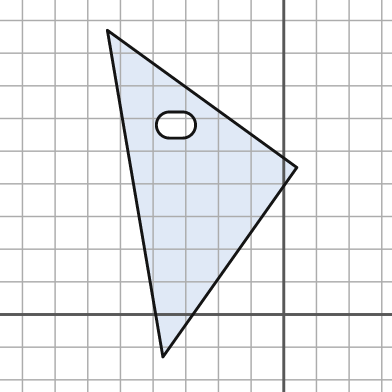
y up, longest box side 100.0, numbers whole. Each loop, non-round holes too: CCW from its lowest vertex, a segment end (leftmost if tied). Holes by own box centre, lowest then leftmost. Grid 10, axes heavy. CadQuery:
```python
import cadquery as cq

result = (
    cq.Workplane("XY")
    .moveTo(-37.0, -13.0)
    .lineTo(4.0, 45.0)
    .lineTo(-54.0, 87.0)
    .close()
    .moveTo(-35.0, 54.0)
    .lineTo(-31.0, 54.0)
    .threePointArc((-27.0, 58.0), (-31.0, 62.0))
    .lineTo(-35.0, 62.0)
    .threePointArc((-39.0, 58.0), (-35.0, 54.0))
    .close()
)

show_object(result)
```